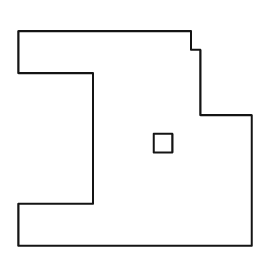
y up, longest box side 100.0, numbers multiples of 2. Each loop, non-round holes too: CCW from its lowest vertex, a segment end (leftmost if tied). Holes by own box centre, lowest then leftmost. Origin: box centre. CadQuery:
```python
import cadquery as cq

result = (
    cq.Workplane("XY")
    .moveTo(-50.0, -46.0)
    .lineTo(50.0, -46.0)
    .lineTo(50.0, 10.0)
    .lineTo(28.0, 10.0)
    .lineTo(28.0, 38.0)
    .lineTo(24.0, 38.0)
    .lineTo(24.0, 46.0)
    .lineTo(-50.0, 46.0)
    .lineTo(-50.0, 28.0)
    .lineTo(-18.0, 28.0)
    .lineTo(-18.0, -28.0)
    .lineTo(-50.0, -28.0)
    .close()
    .moveTo(8.0, -6.0)
    .lineTo(16.0, -6.0)
    .lineTo(16.0, 2.0)
    .lineTo(8.0, 2.0)
    .close()
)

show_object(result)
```